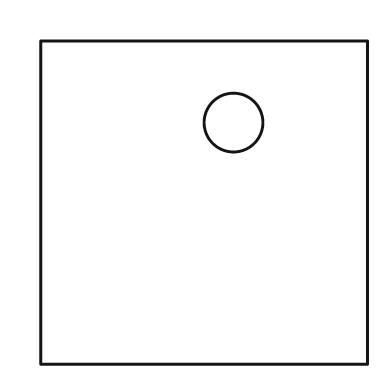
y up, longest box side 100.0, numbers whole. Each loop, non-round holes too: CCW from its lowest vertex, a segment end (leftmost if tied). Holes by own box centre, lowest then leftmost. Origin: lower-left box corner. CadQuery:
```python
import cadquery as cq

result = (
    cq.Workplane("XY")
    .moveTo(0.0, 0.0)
    .lineTo(100.0, 0.0)
    .lineTo(100.0, 99.0)
    .lineTo(0.0, 99.0)
    .close()
    .moveTo(59.0, 74.0)
    .circle(9.0)
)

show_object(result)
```